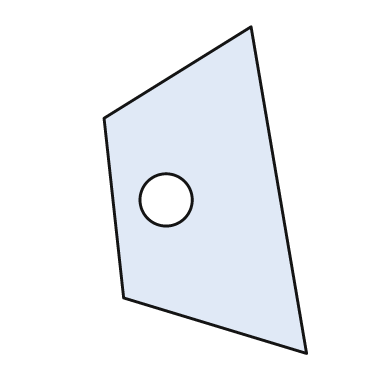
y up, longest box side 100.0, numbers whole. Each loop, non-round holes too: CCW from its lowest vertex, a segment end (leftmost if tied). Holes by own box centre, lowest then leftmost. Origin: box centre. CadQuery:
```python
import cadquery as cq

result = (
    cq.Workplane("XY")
    .moveTo(31.0, -50.0)
    .lineTo(14.0, 50.0)
    .lineTo(-31.0, 22.0)
    .lineTo(-25.0, -33.0)
    .close()
    .moveTo(-12.0, -3.0)
    .circle(8.0)
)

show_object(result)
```